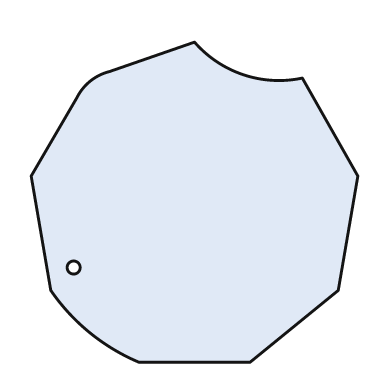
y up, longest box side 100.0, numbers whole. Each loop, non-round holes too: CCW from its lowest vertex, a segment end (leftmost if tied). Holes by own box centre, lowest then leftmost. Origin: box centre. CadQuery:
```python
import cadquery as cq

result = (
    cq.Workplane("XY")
    .moveTo(-17.0, -49.0)
    .lineTo(17.0, -49.0)
    .lineTo(44.0, -27.0)
    .lineTo(50.0, 8.0)
    .lineTo(33.0, 38.0)
    .threePointArc((15.0, 39.0), (0.0, 49.0))
    .lineTo(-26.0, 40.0)
    .threePointArc((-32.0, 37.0), (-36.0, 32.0))
    .lineTo(-50.0, 8.0)
    .lineTo(-44.0, -27.0)
    .threePointArc((-32.0, -40.0), (-17.0, -49.0))
    .close()
    .moveTo(-37.0, -20.0)
    .circle(2.0)
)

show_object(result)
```